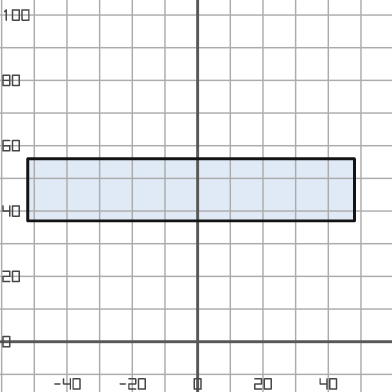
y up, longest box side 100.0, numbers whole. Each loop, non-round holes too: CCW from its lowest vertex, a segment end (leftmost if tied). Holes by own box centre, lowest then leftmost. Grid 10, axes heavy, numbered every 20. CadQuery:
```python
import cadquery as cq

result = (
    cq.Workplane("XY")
    .moveTo(-52.0, 37.0)
    .lineTo(48.0, 37.0)
    .lineTo(48.0, 56.0)
    .lineTo(-52.0, 56.0)
    .close()
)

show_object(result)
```